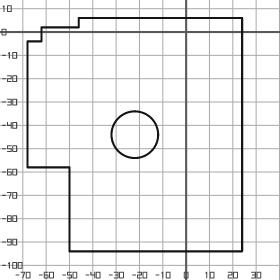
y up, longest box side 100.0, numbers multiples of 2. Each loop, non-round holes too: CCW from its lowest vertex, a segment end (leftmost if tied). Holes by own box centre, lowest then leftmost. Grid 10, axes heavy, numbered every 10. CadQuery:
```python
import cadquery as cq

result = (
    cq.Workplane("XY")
    .moveTo(-50.0, -94.0)
    .lineTo(24.0, -94.0)
    .lineTo(24.0, 6.0)
    .lineTo(-46.0, 6.0)
    .lineTo(-46.0, 2.0)
    .lineTo(-62.0, 2.0)
    .lineTo(-62.0, -4.0)
    .lineTo(-68.0, -4.0)
    .lineTo(-68.0, -58.0)
    .lineTo(-50.0, -58.0)
    .close()
    .moveTo(-22.0, -44.0)
    .circle(10.0)
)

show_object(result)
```